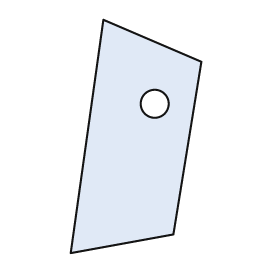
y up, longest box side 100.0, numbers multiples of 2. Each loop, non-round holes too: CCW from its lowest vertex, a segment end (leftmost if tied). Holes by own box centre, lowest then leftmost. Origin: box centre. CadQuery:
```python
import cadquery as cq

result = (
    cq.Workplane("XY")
    .moveTo(-28.0, -50.0)
    .lineTo(16.0, -42.0)
    .lineTo(28.0, 32.0)
    .lineTo(-14.0, 50.0)
    .close()
    .moveTo(8.0, 14.0)
    .circle(6.0)
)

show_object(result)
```